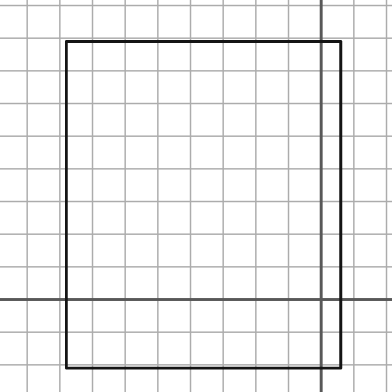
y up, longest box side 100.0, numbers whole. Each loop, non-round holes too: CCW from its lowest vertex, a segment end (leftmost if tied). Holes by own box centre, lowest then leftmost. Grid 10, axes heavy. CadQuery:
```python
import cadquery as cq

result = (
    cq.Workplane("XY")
    .moveTo(-78.0, -21.0)
    .lineTo(6.0, -21.0)
    .lineTo(6.0, 79.0)
    .lineTo(-78.0, 79.0)
    .close()
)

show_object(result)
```